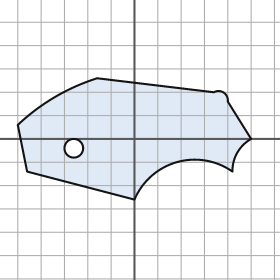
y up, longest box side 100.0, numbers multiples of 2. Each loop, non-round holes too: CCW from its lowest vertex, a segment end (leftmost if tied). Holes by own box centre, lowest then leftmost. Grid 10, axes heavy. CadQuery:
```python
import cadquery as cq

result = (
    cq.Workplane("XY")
    .moveTo(0.0, -26.0)
    .threePointArc((18.0, -10.0), (42.0, -14.0))
    .threePointArc((44.0, -6.0), (50.0, 0.0))
    .lineTo(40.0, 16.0)
    .threePointArc((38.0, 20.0), (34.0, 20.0))
    .lineTo(-16.0, 26.0)
    .threePointArc((-34.0, 18.0), (-50.0, 6.0))
    .lineTo(-46.0, -14.0)
    .close()
    .moveTo(-26.0, -4.0)
    .circle(4.0)
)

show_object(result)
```